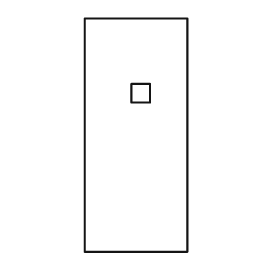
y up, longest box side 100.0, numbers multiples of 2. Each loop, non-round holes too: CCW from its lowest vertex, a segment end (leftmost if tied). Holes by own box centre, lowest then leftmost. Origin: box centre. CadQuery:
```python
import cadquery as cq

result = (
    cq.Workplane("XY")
    .moveTo(-22.0, -50.0)
    .lineTo(22.0, -50.0)
    .lineTo(22.0, 50.0)
    .lineTo(-22.0, 50.0)
    .close()
    .moveTo(-2.0, 14.0)
    .lineTo(6.0, 14.0)
    .lineTo(6.0, 22.0)
    .lineTo(-2.0, 22.0)
    .close()
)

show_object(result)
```